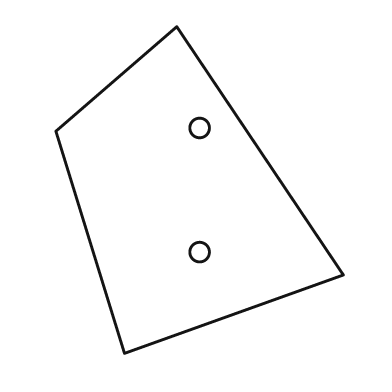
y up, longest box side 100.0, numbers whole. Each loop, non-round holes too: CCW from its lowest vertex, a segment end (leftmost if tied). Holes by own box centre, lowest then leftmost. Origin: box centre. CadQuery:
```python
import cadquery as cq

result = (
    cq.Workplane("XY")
    .moveTo(-23.0, -50.0)
    .lineTo(44.0, -26.0)
    .lineTo(-7.0, 50.0)
    .lineTo(-44.0, 18.0)
    .close()
    .moveTo(0.0, -19.0)
    .circle(3.0)
    .moveTo(0.0, 19.0)
    .circle(3.0)
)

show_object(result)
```